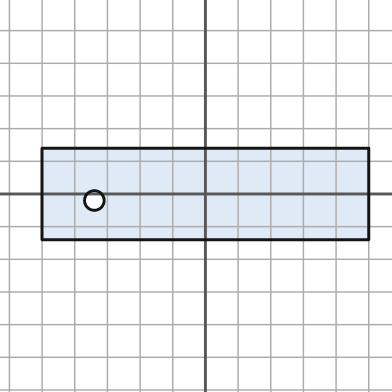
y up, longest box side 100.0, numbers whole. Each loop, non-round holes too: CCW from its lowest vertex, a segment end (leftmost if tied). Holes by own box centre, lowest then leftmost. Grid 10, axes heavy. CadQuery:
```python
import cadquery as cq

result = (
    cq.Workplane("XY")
    .moveTo(-50.0, -14.0)
    .lineTo(50.0, -14.0)
    .lineTo(50.0, 14.0)
    .lineTo(-50.0, 14.0)
    .close()
    .moveTo(-34.0, -2.0)
    .circle(3.0)
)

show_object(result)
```